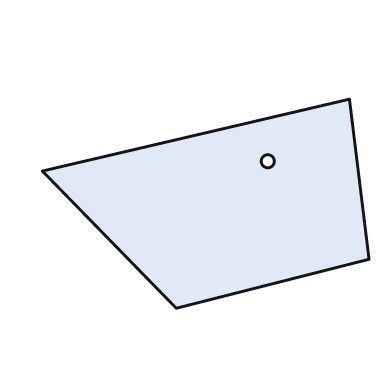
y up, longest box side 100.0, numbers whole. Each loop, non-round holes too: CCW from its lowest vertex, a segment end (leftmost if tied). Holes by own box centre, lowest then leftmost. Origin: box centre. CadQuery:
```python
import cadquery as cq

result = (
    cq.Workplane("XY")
    .moveTo(-9.0, -32.0)
    .lineTo(50.0, -17.0)
    .lineTo(44.0, 32.0)
    .lineTo(-50.0, 10.0)
    .close()
    .moveTo(19.0, 13.0)
    .circle(2.0)
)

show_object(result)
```